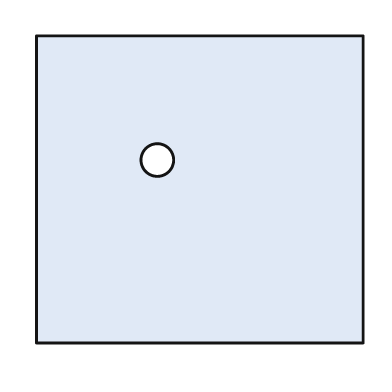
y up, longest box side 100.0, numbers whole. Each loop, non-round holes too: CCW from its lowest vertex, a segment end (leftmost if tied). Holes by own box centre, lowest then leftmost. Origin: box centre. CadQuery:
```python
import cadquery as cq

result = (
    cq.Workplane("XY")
    .moveTo(-50.0, -47.0)
    .lineTo(50.0, -47.0)
    .lineTo(50.0, 47.0)
    .lineTo(-50.0, 47.0)
    .close()
    .moveTo(-13.0, 9.0)
    .circle(5.0)
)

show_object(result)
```